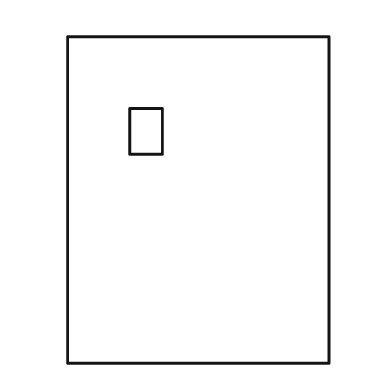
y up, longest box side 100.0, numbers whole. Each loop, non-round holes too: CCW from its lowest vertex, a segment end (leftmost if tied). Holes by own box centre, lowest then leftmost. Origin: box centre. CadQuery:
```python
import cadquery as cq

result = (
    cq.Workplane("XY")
    .moveTo(-40.0, -50.0)
    .lineTo(40.0, -50.0)
    .lineTo(40.0, 50.0)
    .lineTo(-40.0, 50.0)
    .close()
    .moveTo(-21.0, 14.0)
    .lineTo(-11.0, 14.0)
    .lineTo(-11.0, 28.0)
    .lineTo(-21.0, 28.0)
    .close()
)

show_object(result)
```